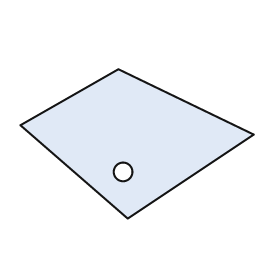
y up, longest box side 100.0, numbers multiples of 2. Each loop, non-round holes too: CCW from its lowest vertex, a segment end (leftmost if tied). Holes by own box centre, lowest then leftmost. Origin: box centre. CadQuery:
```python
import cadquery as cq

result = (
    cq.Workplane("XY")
    .moveTo(-4.0, -32.0)
    .lineTo(50.0, 4.0)
    .lineTo(-8.0, 32.0)
    .lineTo(-50.0, 8.0)
    .close()
    .moveTo(-6.0, -12.0)
    .circle(4.0)
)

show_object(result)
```